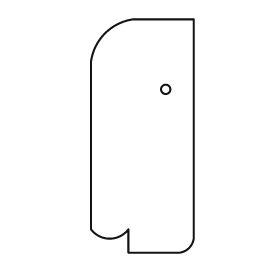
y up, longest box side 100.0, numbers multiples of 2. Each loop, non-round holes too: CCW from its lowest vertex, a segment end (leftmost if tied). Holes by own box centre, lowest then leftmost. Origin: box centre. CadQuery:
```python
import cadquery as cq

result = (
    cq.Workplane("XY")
    .moveTo(-6.0, -50.0)
    .lineTo(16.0, -50.0)
    .threePointArc((20.0, -48.0), (22.0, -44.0))
    .lineTo(22.0, 50.0)
    .lineTo(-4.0, 50.0)
    .threePointArc((-16.0, 44.0), (-22.0, 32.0))
    .lineTo(-22.0, -40.0)
    .threePointArc((-14.0, -44.0), (-6.0, -40.0))
    .close()
    .moveTo(10.0, 20.0)
    .circle(2.0)
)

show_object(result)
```